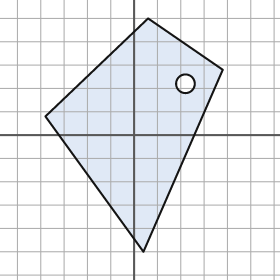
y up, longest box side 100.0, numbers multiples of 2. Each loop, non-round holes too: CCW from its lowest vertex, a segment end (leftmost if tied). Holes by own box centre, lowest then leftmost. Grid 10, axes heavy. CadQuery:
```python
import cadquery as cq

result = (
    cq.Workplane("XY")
    .moveTo(4.0, -50.0)
    .lineTo(38.0, 28.0)
    .lineTo(6.0, 50.0)
    .lineTo(-38.0, 8.0)
    .close()
    .moveTo(22.0, 22.0)
    .circle(4.0)
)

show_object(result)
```